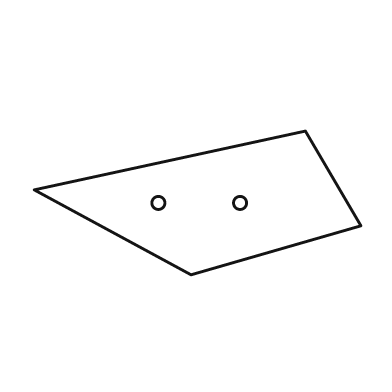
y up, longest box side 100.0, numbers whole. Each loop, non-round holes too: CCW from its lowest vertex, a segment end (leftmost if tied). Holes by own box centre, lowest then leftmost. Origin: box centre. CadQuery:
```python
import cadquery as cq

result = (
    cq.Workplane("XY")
    .moveTo(-2.0, -22.0)
    .lineTo(50.0, -7.0)
    .lineTo(33.0, 22.0)
    .lineTo(-50.0, 4.0)
    .close()
    .moveTo(-12.0, 0.0)
    .circle(2.0)
    .moveTo(13.0, 0.0)
    .circle(2.0)
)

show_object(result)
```